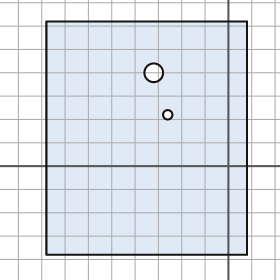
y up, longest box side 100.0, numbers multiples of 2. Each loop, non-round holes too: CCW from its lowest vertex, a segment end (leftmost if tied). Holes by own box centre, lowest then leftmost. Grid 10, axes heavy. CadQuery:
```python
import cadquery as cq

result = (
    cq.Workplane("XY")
    .moveTo(-78.0, -38.0)
    .lineTo(8.0, -38.0)
    .lineTo(8.0, 62.0)
    .lineTo(-78.0, 62.0)
    .close()
    .moveTo(-26.0, 22.0)
    .circle(2.0)
    .moveTo(-32.0, 40.0)
    .circle(4.0)
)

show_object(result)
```